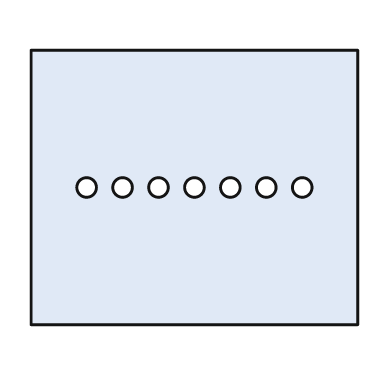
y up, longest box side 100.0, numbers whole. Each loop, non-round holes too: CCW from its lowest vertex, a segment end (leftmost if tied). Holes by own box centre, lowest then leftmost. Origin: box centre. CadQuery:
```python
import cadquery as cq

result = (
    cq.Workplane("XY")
    .moveTo(-50.0, -42.0)
    .lineTo(50.0, -42.0)
    .lineTo(50.0, 42.0)
    .lineTo(-50.0, 42.0)
    .close()
    .moveTo(-33.0, 0.0)
    .circle(3.0)
    .moveTo(-22.0, 0.0)
    .circle(3.0)
    .moveTo(-11.0, 0.0)
    .circle(3.0)
    .moveTo(0.0, 0.0)
    .circle(3.0)
    .moveTo(11.0, 0.0)
    .circle(3.0)
    .moveTo(22.0, 0.0)
    .circle(3.0)
    .moveTo(33.0, 0.0)
    .circle(3.0)
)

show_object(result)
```